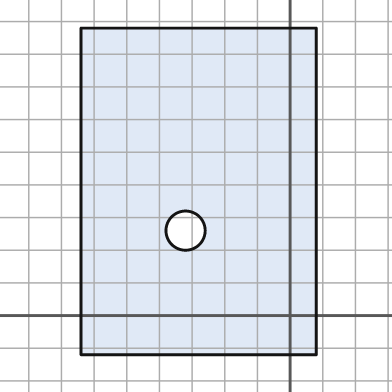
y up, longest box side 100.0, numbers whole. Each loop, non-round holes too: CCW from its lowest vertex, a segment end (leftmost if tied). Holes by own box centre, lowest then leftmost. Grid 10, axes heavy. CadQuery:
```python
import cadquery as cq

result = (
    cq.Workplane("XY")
    .moveTo(-64.0, -12.0)
    .lineTo(8.0, -12.0)
    .lineTo(8.0, 88.0)
    .lineTo(-64.0, 88.0)
    .close()
    .moveTo(-32.0, 26.0)
    .circle(6.0)
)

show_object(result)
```